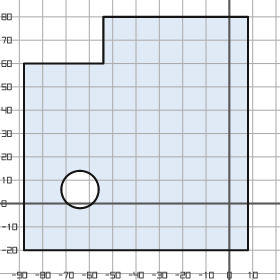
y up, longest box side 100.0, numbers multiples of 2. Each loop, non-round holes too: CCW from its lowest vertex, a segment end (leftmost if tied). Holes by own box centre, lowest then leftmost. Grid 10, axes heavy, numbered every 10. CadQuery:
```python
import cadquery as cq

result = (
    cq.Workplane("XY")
    .moveTo(-88.0, -20.0)
    .lineTo(8.0, -20.0)
    .lineTo(8.0, 80.0)
    .lineTo(-54.0, 80.0)
    .lineTo(-54.0, 60.0)
    .lineTo(-88.0, 60.0)
    .close()
    .moveTo(-64.0, 6.0)
    .circle(8.0)
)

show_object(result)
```